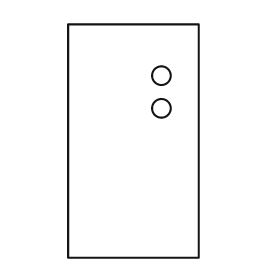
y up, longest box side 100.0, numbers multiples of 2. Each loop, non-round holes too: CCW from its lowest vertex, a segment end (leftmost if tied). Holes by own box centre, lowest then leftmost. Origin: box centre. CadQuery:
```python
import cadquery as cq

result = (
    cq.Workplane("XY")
    .moveTo(-28.0, -50.0)
    .lineTo(28.0, -50.0)
    .lineTo(28.0, 50.0)
    .lineTo(-28.0, 50.0)
    .close()
    .moveTo(12.0, 14.0)
    .circle(4.0)
    .moveTo(12.0, 28.0)
    .circle(4.0)
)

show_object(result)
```